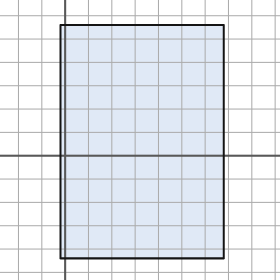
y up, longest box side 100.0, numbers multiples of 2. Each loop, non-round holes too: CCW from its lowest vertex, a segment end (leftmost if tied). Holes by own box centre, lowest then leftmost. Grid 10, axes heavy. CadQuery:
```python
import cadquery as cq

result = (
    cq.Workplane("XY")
    .moveTo(-2.0, -44.0)
    .lineTo(68.0, -44.0)
    .lineTo(68.0, 56.0)
    .lineTo(-2.0, 56.0)
    .close()
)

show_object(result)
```